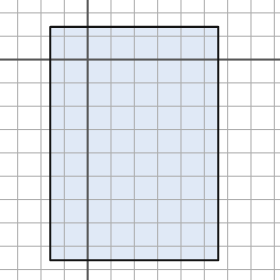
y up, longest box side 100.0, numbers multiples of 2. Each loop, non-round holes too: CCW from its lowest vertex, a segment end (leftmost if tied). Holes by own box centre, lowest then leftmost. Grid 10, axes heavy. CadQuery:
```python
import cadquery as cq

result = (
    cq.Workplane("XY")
    .moveTo(-16.0, -86.0)
    .lineTo(56.0, -86.0)
    .lineTo(56.0, 14.0)
    .lineTo(-16.0, 14.0)
    .close()
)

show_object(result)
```